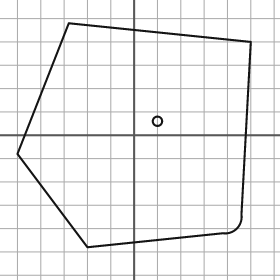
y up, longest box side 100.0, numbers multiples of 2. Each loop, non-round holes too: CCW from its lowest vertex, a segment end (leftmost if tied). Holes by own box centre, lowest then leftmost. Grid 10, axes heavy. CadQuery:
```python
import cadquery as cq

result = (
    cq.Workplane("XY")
    .moveTo(-20.0, -48.0)
    .lineTo(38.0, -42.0)
    .threePointArc((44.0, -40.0), (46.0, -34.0))
    .lineTo(50.0, 40.0)
    .lineTo(-28.0, 48.0)
    .lineTo(-50.0, -8.0)
    .close()
    .moveTo(10.0, 6.0)
    .circle(2.0)
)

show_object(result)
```